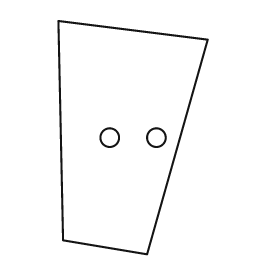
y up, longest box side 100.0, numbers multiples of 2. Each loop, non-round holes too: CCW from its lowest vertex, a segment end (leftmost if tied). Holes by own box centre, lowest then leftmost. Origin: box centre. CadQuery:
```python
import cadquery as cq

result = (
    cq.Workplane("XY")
    .moveTo(6.0, -50.0)
    .lineTo(32.0, 42.0)
    .lineTo(-32.0, 50.0)
    .lineTo(-30.0, -44.0)
    .close()
    .moveTo(-10.0, 0.0)
    .circle(4.0)
    .moveTo(10.0, 0.0)
    .circle(4.0)
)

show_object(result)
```